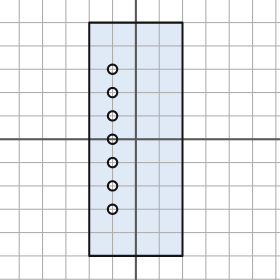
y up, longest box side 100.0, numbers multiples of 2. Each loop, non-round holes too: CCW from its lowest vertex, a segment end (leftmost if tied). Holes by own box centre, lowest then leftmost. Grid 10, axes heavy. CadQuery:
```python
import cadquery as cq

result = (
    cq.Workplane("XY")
    .moveTo(-20.0, -50.0)
    .lineTo(20.0, -50.0)
    .lineTo(20.0, 50.0)
    .lineTo(-20.0, 50.0)
    .close()
    .moveTo(-10.0, -30.0)
    .circle(2.0)
    .moveTo(-10.0, -20.0)
    .circle(2.0)
    .moveTo(-10.0, -10.0)
    .circle(2.0)
    .moveTo(-10.0, 0.0)
    .circle(2.0)
    .moveTo(-10.0, 10.0)
    .circle(2.0)
    .moveTo(-10.0, 20.0)
    .circle(2.0)
    .moveTo(-10.0, 30.0)
    .circle(2.0)
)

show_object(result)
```